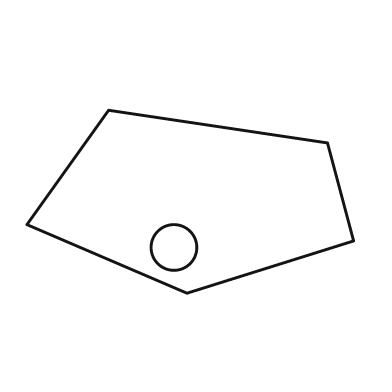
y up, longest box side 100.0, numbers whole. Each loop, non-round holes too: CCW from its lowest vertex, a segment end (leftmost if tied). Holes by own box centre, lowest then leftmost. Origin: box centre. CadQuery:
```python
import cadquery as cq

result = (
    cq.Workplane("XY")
    .moveTo(-1.0, -28.0)
    .lineTo(50.0, -12.0)
    .lineTo(42.0, 18.0)
    .lineTo(-25.0, 28.0)
    .lineTo(-50.0, -7.0)
    .close()
    .moveTo(-5.0, -14.0)
    .circle(7.0)
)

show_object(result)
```